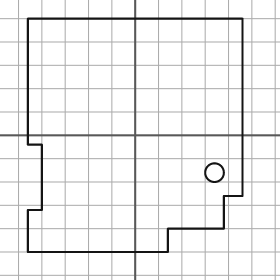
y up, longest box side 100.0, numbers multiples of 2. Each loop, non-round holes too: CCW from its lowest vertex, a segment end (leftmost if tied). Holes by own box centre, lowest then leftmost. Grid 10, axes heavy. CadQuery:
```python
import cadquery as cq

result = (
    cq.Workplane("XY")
    .moveTo(-46.0, -50.0)
    .lineTo(14.0, -50.0)
    .lineTo(14.0, -40.0)
    .lineTo(38.0, -40.0)
    .lineTo(38.0, -26.0)
    .lineTo(46.0, -26.0)
    .lineTo(46.0, 50.0)
    .lineTo(-46.0, 50.0)
    .lineTo(-46.0, -4.0)
    .lineTo(-40.0, -4.0)
    .lineTo(-40.0, -32.0)
    .lineTo(-46.0, -32.0)
    .close()
    .moveTo(34.0, -16.0)
    .circle(4.0)
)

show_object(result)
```